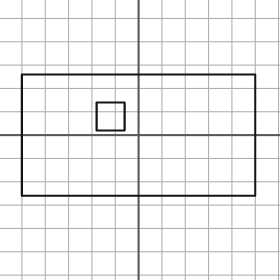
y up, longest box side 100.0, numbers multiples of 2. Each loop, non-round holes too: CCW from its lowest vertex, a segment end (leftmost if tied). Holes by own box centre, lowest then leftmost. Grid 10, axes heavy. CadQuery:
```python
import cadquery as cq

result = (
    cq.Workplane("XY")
    .moveTo(-50.0, -26.0)
    .lineTo(50.0, -26.0)
    .lineTo(50.0, 26.0)
    .lineTo(-50.0, 26.0)
    .close()
    .moveTo(-18.0, 2.0)
    .lineTo(-6.0, 2.0)
    .lineTo(-6.0, 14.0)
    .lineTo(-18.0, 14.0)
    .close()
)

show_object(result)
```